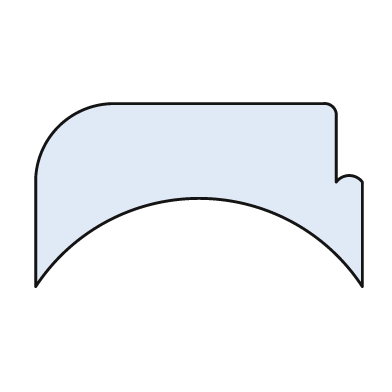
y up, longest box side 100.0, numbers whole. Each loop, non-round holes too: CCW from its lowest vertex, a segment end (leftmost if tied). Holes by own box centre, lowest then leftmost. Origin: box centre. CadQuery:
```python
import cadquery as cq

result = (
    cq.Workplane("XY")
    .moveTo(-50.0, -28.0)
    .threePointArc((0.0, -1.0), (50.0, -28.0))
    .lineTo(50.0, 4.0)
    .threePointArc((46.0, 6.0), (42.0, 4.0))
    .lineTo(42.0, 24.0)
    .threePointArc((41.0, 27.0), (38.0, 28.0))
    .lineTo(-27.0, 28.0)
    .threePointArc((-43.0, 21.0), (-50.0, 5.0))
    .close()
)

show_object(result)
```